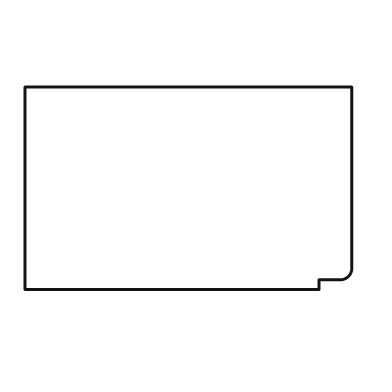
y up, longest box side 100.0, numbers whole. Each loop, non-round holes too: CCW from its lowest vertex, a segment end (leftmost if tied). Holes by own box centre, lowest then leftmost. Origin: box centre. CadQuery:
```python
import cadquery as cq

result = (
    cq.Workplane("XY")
    .moveTo(-50.0, -31.0)
    .lineTo(40.0, -31.0)
    .lineTo(40.0, -28.0)
    .lineTo(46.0, -28.0)
    .threePointArc((49.0, -27.0), (50.0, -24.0))
    .lineTo(50.0, 31.0)
    .lineTo(-50.0, 31.0)
    .close()
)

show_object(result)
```